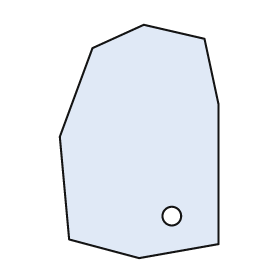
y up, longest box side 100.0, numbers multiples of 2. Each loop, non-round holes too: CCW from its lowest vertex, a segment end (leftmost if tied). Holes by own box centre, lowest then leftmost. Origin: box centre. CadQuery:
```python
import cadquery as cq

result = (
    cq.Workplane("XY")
    .moveTo(0.0, -50.0)
    .lineTo(34.0, -44.0)
    .lineTo(34.0, 16.0)
    .lineTo(28.0, 44.0)
    .lineTo(2.0, 50.0)
    .lineTo(-20.0, 40.0)
    .lineTo(-34.0, 2.0)
    .lineTo(-30.0, -42.0)
    .close()
    .moveTo(14.0, -32.0)
    .circle(4.0)
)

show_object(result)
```